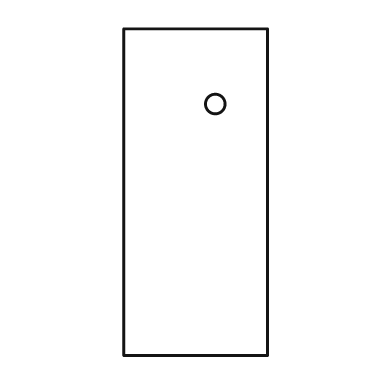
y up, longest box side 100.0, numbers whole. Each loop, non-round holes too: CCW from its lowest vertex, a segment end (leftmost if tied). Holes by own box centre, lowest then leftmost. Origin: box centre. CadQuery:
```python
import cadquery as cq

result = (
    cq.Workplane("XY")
    .moveTo(-22.0, -50.0)
    .lineTo(22.0, -50.0)
    .lineTo(22.0, 50.0)
    .lineTo(-22.0, 50.0)
    .close()
    .moveTo(6.0, 27.0)
    .circle(3.0)
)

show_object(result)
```